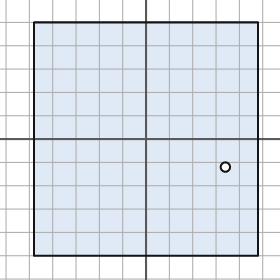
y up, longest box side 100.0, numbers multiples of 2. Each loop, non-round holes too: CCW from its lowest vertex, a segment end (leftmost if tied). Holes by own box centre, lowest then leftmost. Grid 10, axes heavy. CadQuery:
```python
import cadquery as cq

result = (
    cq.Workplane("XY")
    .moveTo(-48.0, -50.0)
    .lineTo(48.0, -50.0)
    .lineTo(48.0, 50.0)
    .lineTo(-48.0, 50.0)
    .close()
    .moveTo(34.0, -12.0)
    .circle(2.0)
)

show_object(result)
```